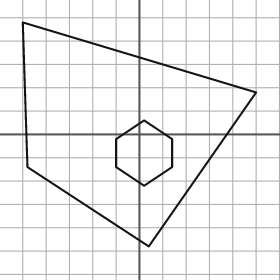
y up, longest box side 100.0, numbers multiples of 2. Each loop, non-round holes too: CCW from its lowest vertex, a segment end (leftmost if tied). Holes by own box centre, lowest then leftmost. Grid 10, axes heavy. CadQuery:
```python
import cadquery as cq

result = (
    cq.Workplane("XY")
    .moveTo(4.0, -48.0)
    .lineTo(50.0, 18.0)
    .lineTo(-50.0, 48.0)
    .lineTo(-48.0, -14.0)
    .close()
    .moveTo(2.0, -22.0)
    .lineTo(14.0, -14.0)
    .lineTo(14.0, -2.0)
    .lineTo(2.0, 6.0)
    .lineTo(-10.0, -2.0)
    .lineTo(-10.0, -14.0)
    .close()
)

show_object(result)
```